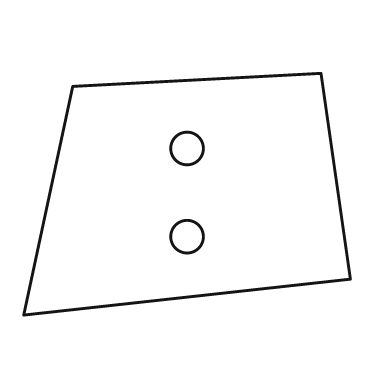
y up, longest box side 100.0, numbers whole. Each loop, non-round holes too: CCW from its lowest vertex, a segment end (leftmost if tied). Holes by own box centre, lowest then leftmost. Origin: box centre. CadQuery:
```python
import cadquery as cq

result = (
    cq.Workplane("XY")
    .moveTo(-50.0, -37.0)
    .lineTo(50.0, -26.0)
    .lineTo(41.0, 37.0)
    .lineTo(-35.0, 33.0)
    .close()
    .moveTo(0.0, -13.0)
    .circle(5.0)
    .moveTo(0.0, 14.0)
    .circle(5.0)
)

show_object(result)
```